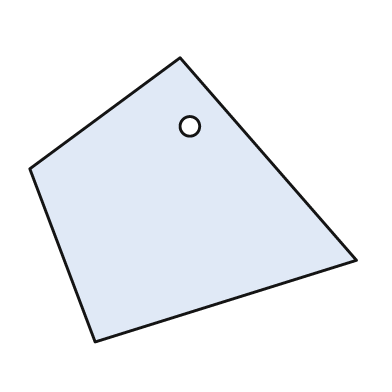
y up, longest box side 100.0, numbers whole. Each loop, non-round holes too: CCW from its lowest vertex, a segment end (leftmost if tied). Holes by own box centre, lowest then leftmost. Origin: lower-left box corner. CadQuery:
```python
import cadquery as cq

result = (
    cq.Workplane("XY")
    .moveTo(20.0, 0.0)
    .lineTo(100.0, 25.0)
    .lineTo(46.0, 87.0)
    .lineTo(0.0, 53.0)
    .close()
    .moveTo(49.0, 66.0)
    .circle(3.0)
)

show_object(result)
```